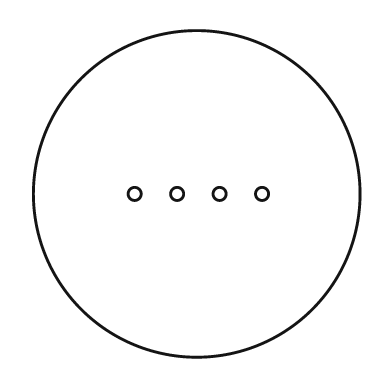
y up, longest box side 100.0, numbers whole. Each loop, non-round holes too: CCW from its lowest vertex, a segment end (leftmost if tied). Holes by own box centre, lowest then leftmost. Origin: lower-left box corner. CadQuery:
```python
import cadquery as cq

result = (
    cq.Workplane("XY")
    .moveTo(50.0, 50.0)
    .circle(50.0)
    .moveTo(31.0, 50.0)
    .circle(2.0)
    .moveTo(44.0, 50.0)
    .circle(2.0)
    .moveTo(57.0, 50.0)
    .circle(2.0)
    .moveTo(70.0, 50.0)
    .circle(2.0)
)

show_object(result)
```